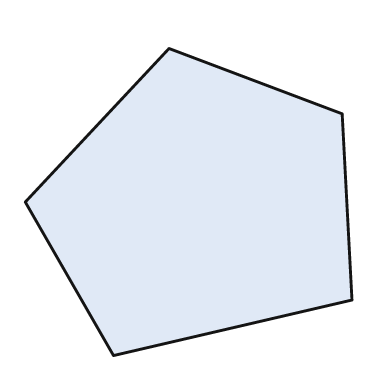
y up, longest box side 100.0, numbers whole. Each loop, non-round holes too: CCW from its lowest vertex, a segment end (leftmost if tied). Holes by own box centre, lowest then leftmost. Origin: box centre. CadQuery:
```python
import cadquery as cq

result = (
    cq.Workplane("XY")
    .moveTo(-23.0, -47.0)
    .lineTo(50.0, -30.0)
    .lineTo(47.0, 27.0)
    .lineTo(-6.0, 47.0)
    .lineTo(-50.0, 0.0)
    .close()
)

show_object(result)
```